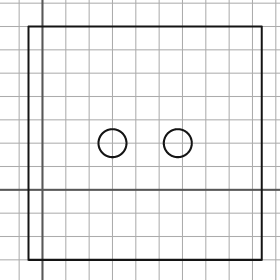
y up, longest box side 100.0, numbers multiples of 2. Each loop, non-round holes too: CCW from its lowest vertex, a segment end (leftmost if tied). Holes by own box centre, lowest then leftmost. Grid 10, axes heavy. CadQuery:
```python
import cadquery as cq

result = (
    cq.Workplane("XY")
    .moveTo(-6.0, -30.0)
    .lineTo(94.0, -30.0)
    .lineTo(94.0, 70.0)
    .lineTo(-6.0, 70.0)
    .close()
    .moveTo(30.0, 20.0)
    .circle(6.0)
    .moveTo(58.0, 20.0)
    .circle(6.0)
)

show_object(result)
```